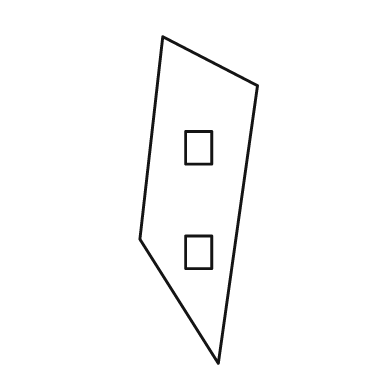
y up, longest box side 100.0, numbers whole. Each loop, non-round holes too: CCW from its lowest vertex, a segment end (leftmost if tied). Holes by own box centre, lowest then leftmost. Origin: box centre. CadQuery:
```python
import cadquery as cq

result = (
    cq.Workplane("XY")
    .moveTo(6.0, -50.0)
    .lineTo(18.0, 35.0)
    .lineTo(-11.0, 50.0)
    .lineTo(-18.0, -12.0)
    .close()
    .moveTo(-4.0, -21.0)
    .lineTo(4.0, -21.0)
    .lineTo(4.0, -11.0)
    .lineTo(-4.0, -11.0)
    .close()
    .moveTo(-4.0, 11.0)
    .lineTo(4.0, 11.0)
    .lineTo(4.0, 21.0)
    .lineTo(-4.0, 21.0)
    .close()
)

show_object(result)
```